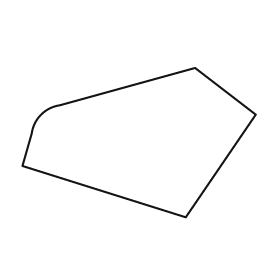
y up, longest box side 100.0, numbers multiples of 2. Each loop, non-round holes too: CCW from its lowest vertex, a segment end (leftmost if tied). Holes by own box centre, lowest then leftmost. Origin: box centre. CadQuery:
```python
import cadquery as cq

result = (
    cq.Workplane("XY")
    .moveTo(20.0, -32.0)
    .lineTo(50.0, 12.0)
    .lineTo(24.0, 32.0)
    .lineTo(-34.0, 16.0)
    .threePointArc((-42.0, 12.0), (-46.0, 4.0))
    .lineTo(-50.0, -10.0)
    .close()
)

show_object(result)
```